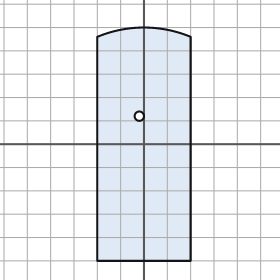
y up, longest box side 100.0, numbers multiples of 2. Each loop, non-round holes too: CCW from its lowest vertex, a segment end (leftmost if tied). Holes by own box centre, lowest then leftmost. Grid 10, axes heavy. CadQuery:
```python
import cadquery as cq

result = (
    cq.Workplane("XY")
    .moveTo(-20.0, -50.0)
    .lineTo(20.0, -50.0)
    .lineTo(20.0, 46.0)
    .threePointArc((0.0, 50.0), (-20.0, 46.0))
    .close()
    .moveTo(-2.0, 12.0)
    .circle(2.0)
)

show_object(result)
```